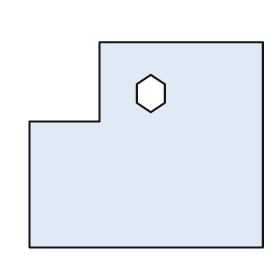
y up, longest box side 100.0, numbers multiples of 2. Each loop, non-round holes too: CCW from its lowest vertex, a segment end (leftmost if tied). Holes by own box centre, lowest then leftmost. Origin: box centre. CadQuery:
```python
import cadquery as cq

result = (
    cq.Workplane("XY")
    .moveTo(-50.0, -44.0)
    .lineTo(50.0, -44.0)
    .lineTo(50.0, 44.0)
    .lineTo(-20.0, 44.0)
    .lineTo(-20.0, 10.0)
    .lineTo(-50.0, 10.0)
    .close()
    .moveTo(2.0, 14.0)
    .lineTo(8.0, 18.0)
    .lineTo(8.0, 26.0)
    .lineTo(2.0, 30.0)
    .lineTo(-4.0, 26.0)
    .lineTo(-4.0, 18.0)
    .close()
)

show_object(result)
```